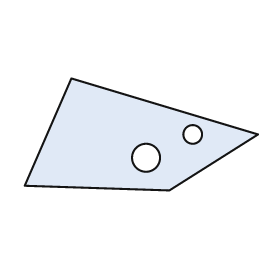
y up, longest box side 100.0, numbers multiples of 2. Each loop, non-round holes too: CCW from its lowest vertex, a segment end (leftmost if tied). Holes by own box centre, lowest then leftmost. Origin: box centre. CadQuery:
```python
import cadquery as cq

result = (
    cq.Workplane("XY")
    .moveTo(12.0, -24.0)
    .lineTo(50.0, 0.0)
    .lineTo(-30.0, 24.0)
    .lineTo(-50.0, -22.0)
    .close()
    .moveTo(2.0, -10.0)
    .circle(6.0)
    .moveTo(22.0, 0.0)
    .circle(4.0)
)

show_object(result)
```